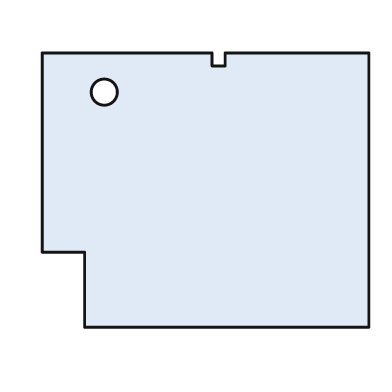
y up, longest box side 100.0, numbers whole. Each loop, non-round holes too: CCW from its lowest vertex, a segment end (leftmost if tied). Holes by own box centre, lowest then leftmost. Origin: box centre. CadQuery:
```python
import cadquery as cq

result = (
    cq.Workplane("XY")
    .moveTo(-37.0, -42.0)
    .lineTo(50.0, -42.0)
    .lineTo(50.0, 42.0)
    .lineTo(6.0, 42.0)
    .lineTo(6.0, 38.0)
    .lineTo(2.0, 38.0)
    .lineTo(2.0, 42.0)
    .lineTo(-50.0, 42.0)
    .lineTo(-50.0, -19.0)
    .lineTo(-37.0, -19.0)
    .close()
    .moveTo(-31.0, 30.0)
    .circle(4.0)
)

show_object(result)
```